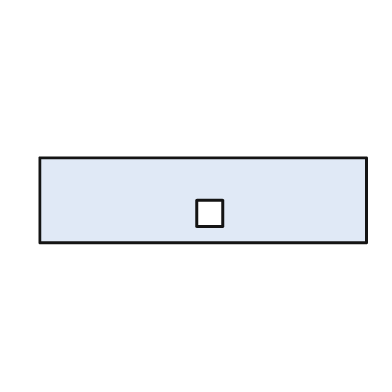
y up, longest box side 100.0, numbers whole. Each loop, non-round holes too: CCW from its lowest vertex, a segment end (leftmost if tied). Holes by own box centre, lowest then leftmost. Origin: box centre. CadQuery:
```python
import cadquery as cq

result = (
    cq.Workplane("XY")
    .moveTo(-50.0, -13.0)
    .lineTo(50.0, -13.0)
    .lineTo(50.0, 13.0)
    .lineTo(-50.0, 13.0)
    .close()
    .moveTo(-2.0, -8.0)
    .lineTo(6.0, -8.0)
    .lineTo(6.0, 0.0)
    .lineTo(-2.0, 0.0)
    .close()
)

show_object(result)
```